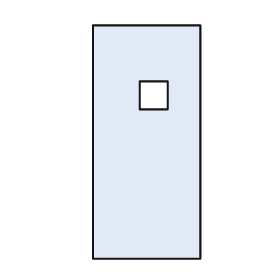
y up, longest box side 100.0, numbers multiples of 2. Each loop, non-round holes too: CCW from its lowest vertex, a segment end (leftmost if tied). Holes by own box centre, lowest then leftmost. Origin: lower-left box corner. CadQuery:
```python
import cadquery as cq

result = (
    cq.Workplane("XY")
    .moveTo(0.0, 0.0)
    .lineTo(46.0, 0.0)
    .lineTo(46.0, 100.0)
    .lineTo(0.0, 100.0)
    .close()
    .moveTo(20.0, 64.0)
    .lineTo(32.0, 64.0)
    .lineTo(32.0, 76.0)
    .lineTo(20.0, 76.0)
    .close()
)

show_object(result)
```